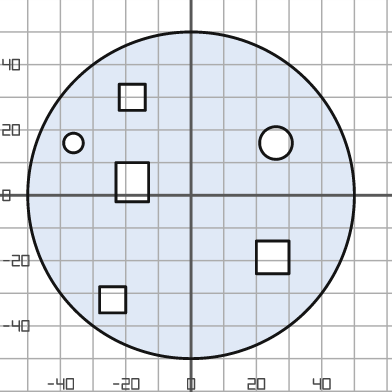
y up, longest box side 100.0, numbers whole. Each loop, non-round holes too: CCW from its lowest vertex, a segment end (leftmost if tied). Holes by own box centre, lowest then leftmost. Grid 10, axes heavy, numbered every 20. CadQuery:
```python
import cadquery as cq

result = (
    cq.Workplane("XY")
    .moveTo(0.0, 0.0)
    .circle(50.0)
    .moveTo(-28.0, -36.0)
    .lineTo(-20.0, -36.0)
    .lineTo(-20.0, -28.0)
    .lineTo(-28.0, -28.0)
    .close()
    .moveTo(20.0, -24.0)
    .lineTo(30.0, -24.0)
    .lineTo(30.0, -14.0)
    .lineTo(20.0, -14.0)
    .close()
    .moveTo(-23.0, -2.0)
    .lineTo(-13.0, -2.0)
    .lineTo(-13.0, 10.0)
    .lineTo(-23.0, 10.0)
    .close()
    .moveTo(-36.0, 16.0)
    .circle(3.0)
    .moveTo(26.0, 16.0)
    .circle(5.0)
    .moveTo(-22.0, 26.0)
    .lineTo(-14.0, 26.0)
    .lineTo(-14.0, 34.0)
    .lineTo(-22.0, 34.0)
    .close()
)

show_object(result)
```